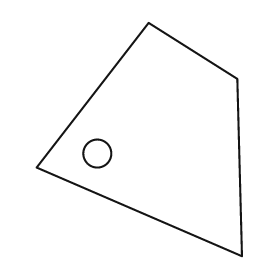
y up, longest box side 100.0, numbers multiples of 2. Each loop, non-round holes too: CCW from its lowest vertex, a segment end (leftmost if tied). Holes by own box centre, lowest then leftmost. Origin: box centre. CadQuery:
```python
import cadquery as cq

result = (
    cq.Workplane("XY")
    .moveTo(44.0, -50.0)
    .lineTo(42.0, 26.0)
    .lineTo(4.0, 50.0)
    .lineTo(-44.0, -12.0)
    .close()
    .moveTo(-18.0, -6.0)
    .circle(6.0)
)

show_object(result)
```